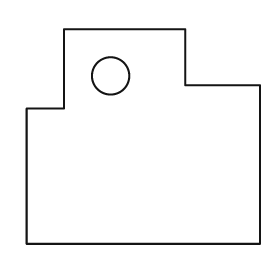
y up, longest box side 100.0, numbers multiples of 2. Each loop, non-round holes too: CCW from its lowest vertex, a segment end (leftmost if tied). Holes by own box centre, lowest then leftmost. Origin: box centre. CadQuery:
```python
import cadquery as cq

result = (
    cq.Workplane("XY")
    .moveTo(-50.0, -46.0)
    .lineTo(50.0, -46.0)
    .lineTo(50.0, 22.0)
    .lineTo(18.0, 22.0)
    .lineTo(18.0, 46.0)
    .lineTo(-34.0, 46.0)
    .lineTo(-34.0, 12.0)
    .lineTo(-50.0, 12.0)
    .close()
    .moveTo(-14.0, 26.0)
    .circle(8.0)
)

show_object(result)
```